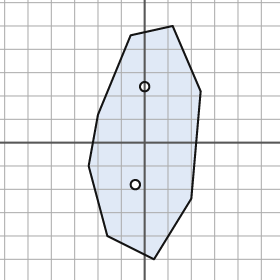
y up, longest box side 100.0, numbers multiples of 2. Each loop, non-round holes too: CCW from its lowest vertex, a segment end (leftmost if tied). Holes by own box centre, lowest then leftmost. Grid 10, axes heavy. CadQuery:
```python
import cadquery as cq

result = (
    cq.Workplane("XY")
    .moveTo(4.0, -50.0)
    .lineTo(20.0, -24.0)
    .lineTo(24.0, 22.0)
    .lineTo(12.0, 50.0)
    .lineTo(-6.0, 46.0)
    .lineTo(-20.0, 12.0)
    .lineTo(-24.0, -10.0)
    .lineTo(-16.0, -40.0)
    .close()
    .moveTo(-4.0, -18.0)
    .circle(2.0)
    .moveTo(0.0, 24.0)
    .circle(2.0)
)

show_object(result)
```